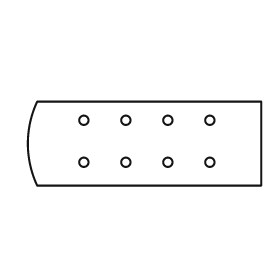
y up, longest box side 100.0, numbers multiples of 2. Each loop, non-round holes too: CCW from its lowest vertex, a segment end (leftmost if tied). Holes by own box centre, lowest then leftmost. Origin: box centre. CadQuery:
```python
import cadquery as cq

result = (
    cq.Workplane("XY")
    .moveTo(-46.0, -18.0)
    .lineTo(50.0, -18.0)
    .lineTo(50.0, 18.0)
    .lineTo(-46.0, 18.0)
    .threePointArc((-50.0, 0.0), (-46.0, -18.0))
    .close()
    .moveTo(-26.0, -8.0)
    .circle(2.0)
    .moveTo(-8.0, -8.0)
    .circle(2.0)
    .moveTo(10.0, -8.0)
    .circle(2.0)
    .moveTo(28.0, -8.0)
    .circle(2.0)
    .moveTo(-26.0, 10.0)
    .circle(2.0)
    .moveTo(-8.0, 10.0)
    .circle(2.0)
    .moveTo(10.0, 10.0)
    .circle(2.0)
    .moveTo(28.0, 10.0)
    .circle(2.0)
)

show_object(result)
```